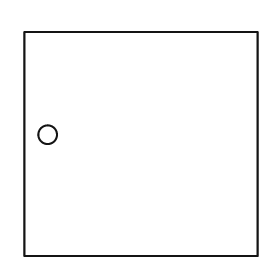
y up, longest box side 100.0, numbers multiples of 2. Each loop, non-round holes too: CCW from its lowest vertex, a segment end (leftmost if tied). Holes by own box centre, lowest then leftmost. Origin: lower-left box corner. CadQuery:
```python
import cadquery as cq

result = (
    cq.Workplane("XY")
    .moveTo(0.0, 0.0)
    .lineTo(100.0, 0.0)
    .lineTo(100.0, 96.0)
    .lineTo(0.0, 96.0)
    .close()
    .moveTo(10.0, 52.0)
    .circle(4.0)
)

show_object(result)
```